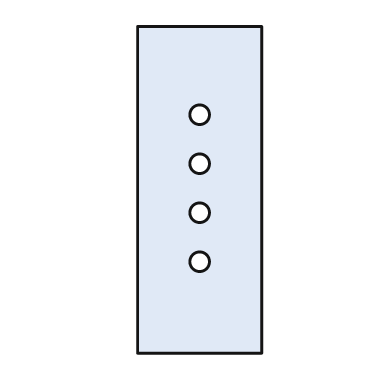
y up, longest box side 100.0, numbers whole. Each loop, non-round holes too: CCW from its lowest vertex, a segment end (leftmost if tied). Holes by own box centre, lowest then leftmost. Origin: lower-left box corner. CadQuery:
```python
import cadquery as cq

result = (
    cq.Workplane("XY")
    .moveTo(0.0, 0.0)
    .lineTo(38.0, 0.0)
    .lineTo(38.0, 100.0)
    .lineTo(0.0, 100.0)
    .close()
    .moveTo(19.0, 28.0)
    .circle(3.0)
    .moveTo(19.0, 43.0)
    .circle(3.0)
    .moveTo(19.0, 58.0)
    .circle(3.0)
    .moveTo(19.0, 73.0)
    .circle(3.0)
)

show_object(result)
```